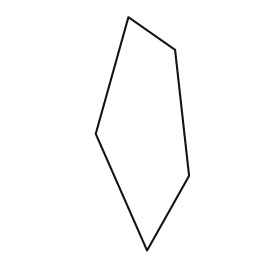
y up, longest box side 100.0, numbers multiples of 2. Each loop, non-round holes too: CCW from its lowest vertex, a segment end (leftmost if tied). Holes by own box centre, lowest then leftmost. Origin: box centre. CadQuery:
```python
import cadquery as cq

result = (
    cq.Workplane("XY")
    .moveTo(2.0, -50.0)
    .lineTo(20.0, -18.0)
    .lineTo(14.0, 36.0)
    .lineTo(-6.0, 50.0)
    .lineTo(-20.0, 0.0)
    .close()
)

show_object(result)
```